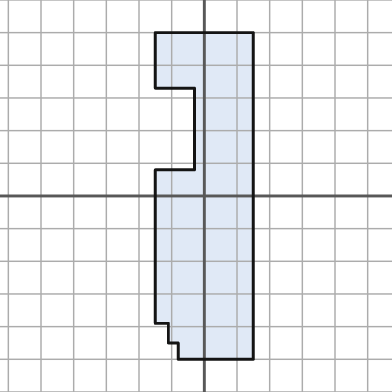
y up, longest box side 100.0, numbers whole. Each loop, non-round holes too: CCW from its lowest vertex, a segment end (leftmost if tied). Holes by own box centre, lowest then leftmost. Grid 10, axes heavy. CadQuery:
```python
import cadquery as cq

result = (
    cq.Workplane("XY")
    .moveTo(-8.0, -50.0)
    .lineTo(15.0, -50.0)
    .lineTo(15.0, 50.0)
    .lineTo(-15.0, 50.0)
    .lineTo(-15.0, 33.0)
    .lineTo(-3.0, 33.0)
    .lineTo(-3.0, 8.0)
    .lineTo(-15.0, 8.0)
    .lineTo(-15.0, -39.0)
    .lineTo(-11.0, -39.0)
    .lineTo(-11.0, -45.0)
    .lineTo(-8.0, -45.0)
    .close()
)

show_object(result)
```